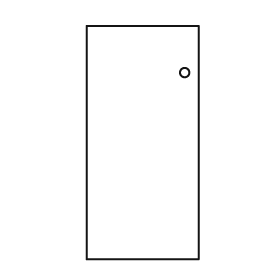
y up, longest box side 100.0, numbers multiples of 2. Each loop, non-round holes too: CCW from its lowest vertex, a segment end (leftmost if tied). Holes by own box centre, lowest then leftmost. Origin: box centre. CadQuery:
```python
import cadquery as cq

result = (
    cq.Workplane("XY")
    .moveTo(-24.0, -50.0)
    .lineTo(24.0, -50.0)
    .lineTo(24.0, 50.0)
    .lineTo(-24.0, 50.0)
    .close()
    .moveTo(18.0, 30.0)
    .circle(2.0)
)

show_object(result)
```